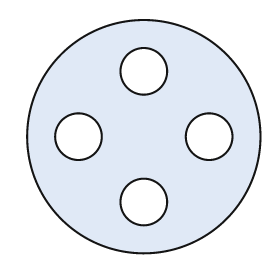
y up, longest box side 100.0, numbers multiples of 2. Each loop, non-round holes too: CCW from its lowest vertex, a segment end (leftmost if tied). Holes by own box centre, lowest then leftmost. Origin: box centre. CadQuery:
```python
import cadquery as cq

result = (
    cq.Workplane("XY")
    .moveTo(0.0, 0.0)
    .circle(50.0)
    .moveTo(0.0, -28.0)
    .circle(10.0)
    .moveTo(-28.0, 0.0)
    .circle(10.0)
    .moveTo(28.0, 0.0)
    .circle(10.0)
    .moveTo(0.0, 28.0)
    .circle(10.0)
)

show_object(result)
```